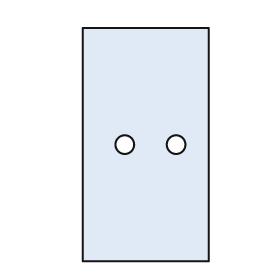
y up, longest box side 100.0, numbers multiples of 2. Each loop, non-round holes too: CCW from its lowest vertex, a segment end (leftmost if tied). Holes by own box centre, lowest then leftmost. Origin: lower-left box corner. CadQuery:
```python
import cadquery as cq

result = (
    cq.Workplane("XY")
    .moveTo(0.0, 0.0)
    .lineTo(54.0, 0.0)
    .lineTo(54.0, 100.0)
    .lineTo(0.0, 100.0)
    .close()
    .moveTo(18.0, 50.0)
    .circle(4.0)
    .moveTo(40.0, 50.0)
    .circle(4.0)
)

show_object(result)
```